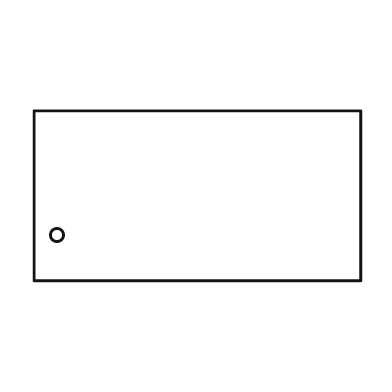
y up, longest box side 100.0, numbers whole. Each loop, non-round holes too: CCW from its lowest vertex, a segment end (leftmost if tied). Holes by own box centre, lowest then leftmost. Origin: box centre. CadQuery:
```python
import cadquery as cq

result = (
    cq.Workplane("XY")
    .moveTo(-50.0, -26.0)
    .lineTo(50.0, -26.0)
    .lineTo(50.0, 26.0)
    .lineTo(-50.0, 26.0)
    .close()
    .moveTo(-43.0, -12.0)
    .circle(2.0)
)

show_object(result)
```